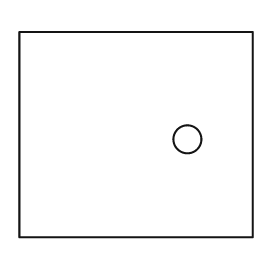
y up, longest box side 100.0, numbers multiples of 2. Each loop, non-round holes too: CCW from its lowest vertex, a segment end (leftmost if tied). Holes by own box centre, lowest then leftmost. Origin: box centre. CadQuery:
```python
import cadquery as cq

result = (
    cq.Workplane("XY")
    .moveTo(-50.0, -44.0)
    .lineTo(50.0, -44.0)
    .lineTo(50.0, 44.0)
    .lineTo(-50.0, 44.0)
    .close()
    .moveTo(22.0, -2.0)
    .circle(6.0)
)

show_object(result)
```